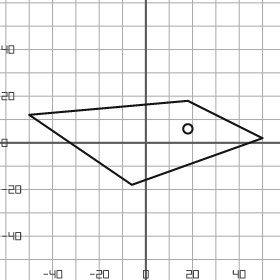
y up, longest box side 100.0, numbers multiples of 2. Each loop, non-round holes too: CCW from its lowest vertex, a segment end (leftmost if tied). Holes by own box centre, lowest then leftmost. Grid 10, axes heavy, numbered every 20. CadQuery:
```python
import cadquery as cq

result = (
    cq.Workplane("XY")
    .moveTo(-6.0, -18.0)
    .lineTo(50.0, 2.0)
    .lineTo(18.0, 18.0)
    .lineTo(-50.0, 12.0)
    .close()
    .moveTo(18.0, 6.0)
    .circle(2.0)
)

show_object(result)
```